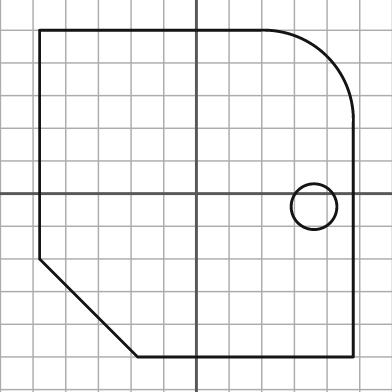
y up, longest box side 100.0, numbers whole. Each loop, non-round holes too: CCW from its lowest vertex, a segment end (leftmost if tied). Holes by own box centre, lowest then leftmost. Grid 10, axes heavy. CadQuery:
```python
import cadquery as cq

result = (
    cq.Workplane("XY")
    .moveTo(-18.0, -50.0)
    .lineTo(48.0, -50.0)
    .lineTo(48.0, 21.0)
    .threePointArc((40.0, 42.0), (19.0, 50.0))
    .lineTo(-48.0, 50.0)
    .lineTo(-48.0, -20.0)
    .close()
    .moveTo(36.0, -4.0)
    .circle(7.0)
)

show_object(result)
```